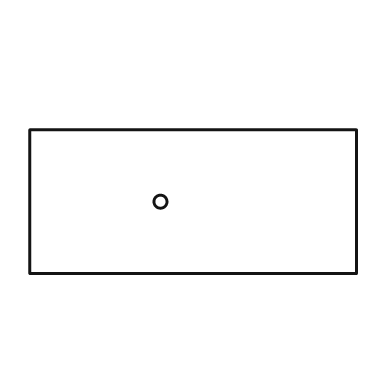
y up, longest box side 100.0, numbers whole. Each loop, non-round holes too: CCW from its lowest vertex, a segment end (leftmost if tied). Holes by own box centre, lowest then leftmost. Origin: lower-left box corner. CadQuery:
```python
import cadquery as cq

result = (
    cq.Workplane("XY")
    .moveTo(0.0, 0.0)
    .lineTo(100.0, 0.0)
    .lineTo(100.0, 44.0)
    .lineTo(0.0, 44.0)
    .close()
    .moveTo(40.0, 22.0)
    .circle(2.0)
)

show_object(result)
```